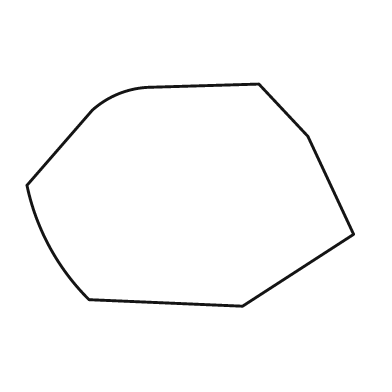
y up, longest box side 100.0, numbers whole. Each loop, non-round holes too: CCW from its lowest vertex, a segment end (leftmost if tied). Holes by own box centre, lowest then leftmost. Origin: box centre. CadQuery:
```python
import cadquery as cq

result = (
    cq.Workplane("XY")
    .moveTo(16.0, -34.0)
    .lineTo(50.0, -12.0)
    .lineTo(36.0, 18.0)
    .lineTo(21.0, 34.0)
    .lineTo(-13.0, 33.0)
    .threePointArc((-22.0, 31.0), (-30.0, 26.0))
    .lineTo(-50.0, 3.0)
    .threePointArc((-43.0, -16.0), (-31.0, -32.0))
    .close()
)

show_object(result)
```